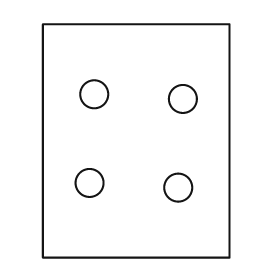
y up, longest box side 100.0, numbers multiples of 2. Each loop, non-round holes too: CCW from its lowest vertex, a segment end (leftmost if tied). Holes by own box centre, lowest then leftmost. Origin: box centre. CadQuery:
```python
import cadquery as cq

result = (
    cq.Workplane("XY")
    .moveTo(-40.0, -50.0)
    .lineTo(40.0, -50.0)
    .lineTo(40.0, 50.0)
    .lineTo(-40.0, 50.0)
    .close()
    .moveTo(18.0, -20.0)
    .circle(6.0)
    .moveTo(-20.0, -18.0)
    .circle(6.0)
    .moveTo(20.0, 18.0)
    .circle(6.0)
    .moveTo(-18.0, 20.0)
    .circle(6.0)
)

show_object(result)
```